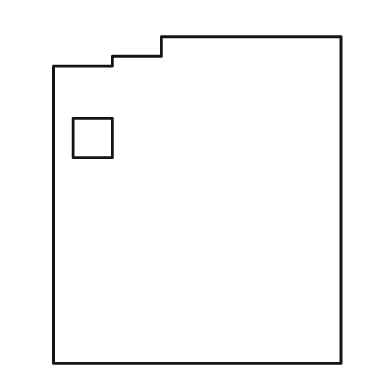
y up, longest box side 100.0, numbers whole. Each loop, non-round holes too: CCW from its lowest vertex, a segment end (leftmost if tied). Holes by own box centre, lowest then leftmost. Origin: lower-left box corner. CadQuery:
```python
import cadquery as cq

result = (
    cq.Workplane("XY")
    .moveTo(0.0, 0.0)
    .lineTo(88.0, 0.0)
    .lineTo(88.0, 100.0)
    .lineTo(33.0, 100.0)
    .lineTo(33.0, 94.0)
    .lineTo(18.0, 94.0)
    .lineTo(18.0, 91.0)
    .lineTo(0.0, 91.0)
    .close()
    .moveTo(6.0, 63.0)
    .lineTo(18.0, 63.0)
    .lineTo(18.0, 75.0)
    .lineTo(6.0, 75.0)
    .close()
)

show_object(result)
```